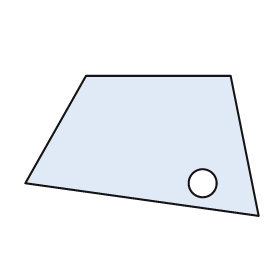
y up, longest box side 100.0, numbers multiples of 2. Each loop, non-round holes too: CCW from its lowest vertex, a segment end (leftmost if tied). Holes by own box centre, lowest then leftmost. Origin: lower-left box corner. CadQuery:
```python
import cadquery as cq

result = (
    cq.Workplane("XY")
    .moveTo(100.0, 0.0)
    .lineTo(88.0, 60.0)
    .lineTo(26.0, 60.0)
    .lineTo(0.0, 14.0)
    .close()
    .moveTo(76.0, 14.0)
    .circle(6.0)
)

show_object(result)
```